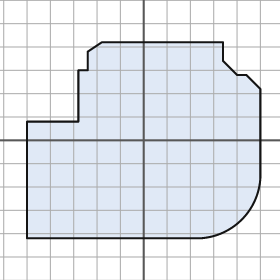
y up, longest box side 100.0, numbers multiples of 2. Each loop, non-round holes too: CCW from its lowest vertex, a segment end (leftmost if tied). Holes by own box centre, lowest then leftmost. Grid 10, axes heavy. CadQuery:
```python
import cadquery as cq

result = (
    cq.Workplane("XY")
    .moveTo(-50.0, -42.0)
    .lineTo(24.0, -42.0)
    .threePointArc((42.0, -34.0), (50.0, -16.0))
    .lineTo(50.0, 22.0)
    .lineTo(44.0, 28.0)
    .lineTo(40.0, 28.0)
    .lineTo(34.0, 34.0)
    .lineTo(34.0, 42.0)
    .lineTo(-18.0, 42.0)
    .lineTo(-24.0, 38.0)
    .lineTo(-24.0, 30.0)
    .lineTo(-28.0, 30.0)
    .lineTo(-28.0, 8.0)
    .lineTo(-50.0, 8.0)
    .close()
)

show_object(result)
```